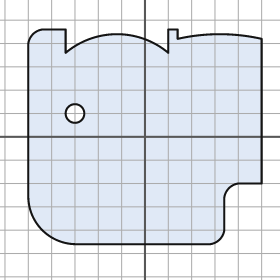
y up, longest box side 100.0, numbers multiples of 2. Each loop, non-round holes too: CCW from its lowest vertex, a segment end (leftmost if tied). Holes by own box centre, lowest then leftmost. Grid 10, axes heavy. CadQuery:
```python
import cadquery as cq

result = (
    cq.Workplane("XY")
    .moveTo(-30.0, -46.0)
    .lineTo(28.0, -46.0)
    .threePointArc((32.0, -44.0), (34.0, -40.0))
    .lineTo(34.0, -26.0)
    .threePointArc((36.0, -22.0), (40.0, -20.0))
    .lineTo(50.0, -20.0)
    .lineTo(50.0, 42.0)
    .threePointArc((32.0, 44.0), (14.0, 42.0))
    .lineTo(14.0, 46.0)
    .lineTo(10.0, 46.0)
    .lineTo(10.0, 36.0)
    .threePointArc((-12.0, 44.0), (-34.0, 36.0))
    .lineTo(-34.0, 46.0)
    .lineTo(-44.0, 46.0)
    .threePointArc((-48.0, 44.0), (-50.0, 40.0))
    .lineTo(-50.0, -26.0)
    .threePointArc((-44.0, -40.0), (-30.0, -46.0))
    .close()
    .moveTo(-30.0, 10.0)
    .circle(4.0)
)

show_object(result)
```